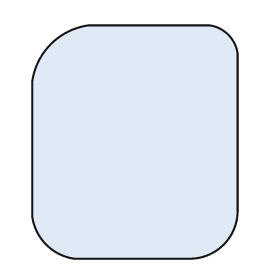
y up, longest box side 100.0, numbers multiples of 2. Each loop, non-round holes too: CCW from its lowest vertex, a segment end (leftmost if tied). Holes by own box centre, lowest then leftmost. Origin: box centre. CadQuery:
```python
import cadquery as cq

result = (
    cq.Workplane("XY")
    .moveTo(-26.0, -50.0)
    .lineTo(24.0, -50.0)
    .threePointArc((38.0, -44.0), (44.0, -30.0))
    .lineTo(44.0, 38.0)
    .threePointArc((40.0, 46.0), (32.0, 50.0))
    .lineTo(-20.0, 50.0)
    .threePointArc((-36.0, 42.0), (-44.0, 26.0))
    .lineTo(-44.0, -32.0)
    .threePointArc((-38.0, -44.0), (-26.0, -50.0))
    .close()
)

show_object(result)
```